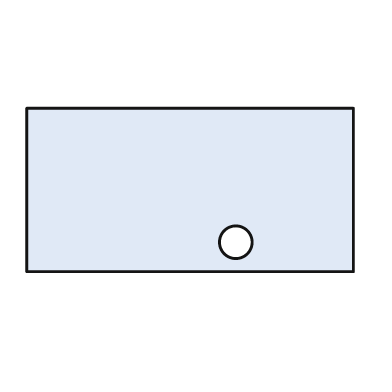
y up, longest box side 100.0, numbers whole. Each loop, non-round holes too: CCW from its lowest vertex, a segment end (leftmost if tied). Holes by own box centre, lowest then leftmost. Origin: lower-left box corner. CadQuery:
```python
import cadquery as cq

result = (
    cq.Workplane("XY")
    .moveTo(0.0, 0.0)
    .lineTo(100.0, 0.0)
    .lineTo(100.0, 50.0)
    .lineTo(0.0, 50.0)
    .close()
    .moveTo(64.0, 9.0)
    .circle(5.0)
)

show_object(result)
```